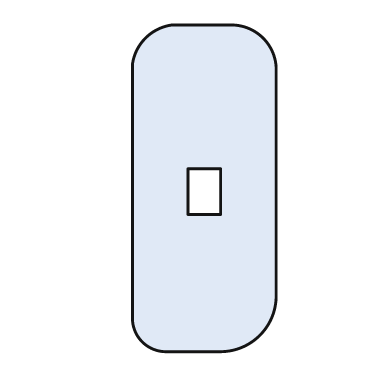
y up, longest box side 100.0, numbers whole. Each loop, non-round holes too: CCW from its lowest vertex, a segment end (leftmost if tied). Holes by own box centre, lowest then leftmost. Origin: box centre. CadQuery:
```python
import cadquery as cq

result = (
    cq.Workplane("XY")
    .moveTo(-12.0, -50.0)
    .lineTo(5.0, -50.0)
    .threePointArc((17.0, -45.0), (22.0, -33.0))
    .lineTo(22.0, 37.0)
    .threePointArc((18.0, 46.0), (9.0, 50.0))
    .lineTo(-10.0, 50.0)
    .threePointArc((-18.0, 46.0), (-22.0, 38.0))
    .lineTo(-22.0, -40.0)
    .threePointArc((-19.0, -47.0), (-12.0, -50.0))
    .close()
    .moveTo(-5.0, -8.0)
    .lineTo(5.0, -8.0)
    .lineTo(5.0, 6.0)
    .lineTo(-5.0, 6.0)
    .close()
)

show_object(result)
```